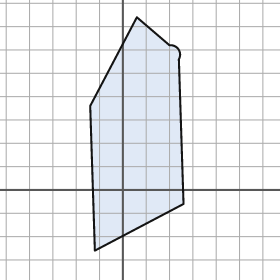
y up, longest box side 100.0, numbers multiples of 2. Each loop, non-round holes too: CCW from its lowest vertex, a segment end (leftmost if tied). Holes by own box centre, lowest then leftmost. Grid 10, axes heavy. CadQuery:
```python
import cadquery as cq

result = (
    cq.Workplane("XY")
    .moveTo(-12.0, -26.0)
    .lineTo(26.0, -6.0)
    .lineTo(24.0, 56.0)
    .threePointArc((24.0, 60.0), (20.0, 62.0))
    .lineTo(6.0, 74.0)
    .lineTo(-14.0, 36.0)
    .close()
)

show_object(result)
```